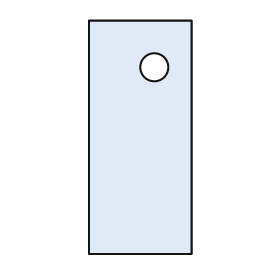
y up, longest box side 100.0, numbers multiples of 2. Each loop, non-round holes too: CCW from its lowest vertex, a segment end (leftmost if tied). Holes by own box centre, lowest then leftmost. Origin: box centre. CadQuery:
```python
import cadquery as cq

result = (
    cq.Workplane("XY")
    .moveTo(-22.0, -50.0)
    .lineTo(22.0, -50.0)
    .lineTo(22.0, 50.0)
    .lineTo(-22.0, 50.0)
    .close()
    .moveTo(6.0, 30.0)
    .circle(6.0)
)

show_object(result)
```